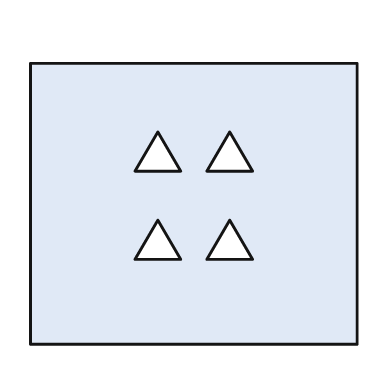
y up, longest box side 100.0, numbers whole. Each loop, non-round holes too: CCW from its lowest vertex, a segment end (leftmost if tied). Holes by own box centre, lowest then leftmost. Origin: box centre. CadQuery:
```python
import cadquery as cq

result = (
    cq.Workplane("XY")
    .moveTo(-50.0, -43.0)
    .lineTo(50.0, -43.0)
    .lineTo(50.0, 43.0)
    .lineTo(-50.0, 43.0)
    .close()
    .moveTo(-18.0, -17.0)
    .lineTo(-4.0, -17.0)
    .lineTo(-11.0, -5.0)
    .close()
    .moveTo(4.0, -17.0)
    .lineTo(18.0, -17.0)
    .lineTo(11.0, -5.0)
    .close()
    .moveTo(-18.0, 10.0)
    .lineTo(-4.0, 10.0)
    .lineTo(-11.0, 22.0)
    .close()
    .moveTo(4.0, 10.0)
    .lineTo(18.0, 10.0)
    .lineTo(11.0, 22.0)
    .close()
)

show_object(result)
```